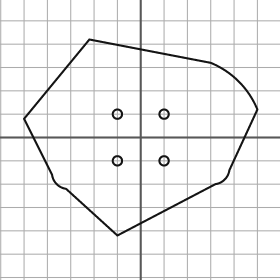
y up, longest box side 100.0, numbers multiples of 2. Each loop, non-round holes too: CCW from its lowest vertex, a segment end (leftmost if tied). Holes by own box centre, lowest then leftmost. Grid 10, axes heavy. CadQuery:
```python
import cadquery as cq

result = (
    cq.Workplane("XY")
    .moveTo(-10.0, -42.0)
    .lineTo(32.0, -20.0)
    .threePointArc((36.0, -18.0), (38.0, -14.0))
    .lineTo(50.0, 12.0)
    .threePointArc((42.0, 24.0), (30.0, 32.0))
    .lineTo(-22.0, 42.0)
    .lineTo(-50.0, 8.0)
    .lineTo(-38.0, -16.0)
    .threePointArc((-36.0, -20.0), (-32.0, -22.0))
    .close()
    .moveTo(-10.0, -10.0)
    .circle(2.0)
    .moveTo(10.0, -10.0)
    .circle(2.0)
    .moveTo(-10.0, 10.0)
    .circle(2.0)
    .moveTo(10.0, 10.0)
    .circle(2.0)
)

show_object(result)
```